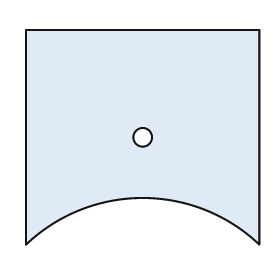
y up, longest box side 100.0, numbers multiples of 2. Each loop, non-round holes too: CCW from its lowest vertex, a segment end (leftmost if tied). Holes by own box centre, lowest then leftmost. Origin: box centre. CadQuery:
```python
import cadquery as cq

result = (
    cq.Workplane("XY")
    .moveTo(-50.0, -46.0)
    .threePointArc((0.0, -26.0), (50.0, -46.0))
    .lineTo(50.0, 46.0)
    .lineTo(-50.0, 46.0)
    .close()
    .moveTo(0.0, 0.0)
    .circle(4.0)
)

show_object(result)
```